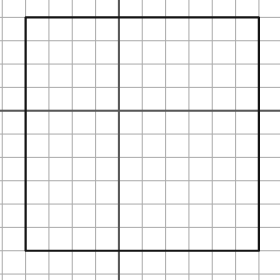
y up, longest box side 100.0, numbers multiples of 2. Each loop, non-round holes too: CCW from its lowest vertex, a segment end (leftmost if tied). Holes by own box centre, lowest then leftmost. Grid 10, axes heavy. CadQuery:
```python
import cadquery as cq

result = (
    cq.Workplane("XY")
    .moveTo(-40.0, -60.0)
    .lineTo(60.0, -60.0)
    .lineTo(60.0, 40.0)
    .lineTo(-40.0, 40.0)
    .close()
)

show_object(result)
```